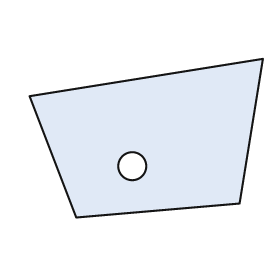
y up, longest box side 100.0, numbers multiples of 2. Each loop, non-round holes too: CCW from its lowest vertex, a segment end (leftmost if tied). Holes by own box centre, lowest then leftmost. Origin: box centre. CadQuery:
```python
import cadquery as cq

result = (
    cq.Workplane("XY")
    .moveTo(-30.0, -34.0)
    .lineTo(40.0, -28.0)
    .lineTo(50.0, 34.0)
    .lineTo(-50.0, 18.0)
    .close()
    .moveTo(-6.0, -12.0)
    .circle(6.0)
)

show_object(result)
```